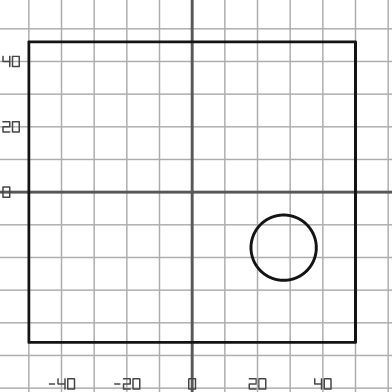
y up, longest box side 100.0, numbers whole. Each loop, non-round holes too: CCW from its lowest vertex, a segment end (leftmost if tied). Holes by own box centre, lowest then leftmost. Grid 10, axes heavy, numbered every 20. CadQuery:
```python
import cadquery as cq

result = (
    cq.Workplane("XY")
    .moveTo(-50.0, -46.0)
    .lineTo(50.0, -46.0)
    .lineTo(50.0, 46.0)
    .lineTo(-50.0, 46.0)
    .close()
    .moveTo(28.0, -17.0)
    .circle(10.0)
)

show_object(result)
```